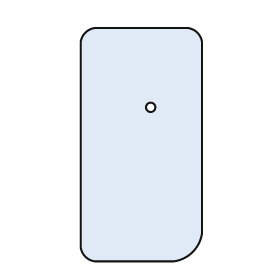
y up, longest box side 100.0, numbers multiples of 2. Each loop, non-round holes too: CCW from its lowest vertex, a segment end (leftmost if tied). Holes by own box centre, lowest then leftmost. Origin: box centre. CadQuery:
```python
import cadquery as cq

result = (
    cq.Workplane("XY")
    .moveTo(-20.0, -50.0)
    .lineTo(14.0, -50.0)
    .threePointArc((22.0, -46.0), (26.0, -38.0))
    .lineTo(26.0, 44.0)
    .threePointArc((24.0, 48.0), (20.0, 50.0))
    .lineTo(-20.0, 50.0)
    .threePointArc((-24.0, 48.0), (-26.0, 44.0))
    .lineTo(-26.0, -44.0)
    .threePointArc((-24.0, -48.0), (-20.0, -50.0))
    .close()
    .moveTo(4.0, 16.0)
    .circle(2.0)
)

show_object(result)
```